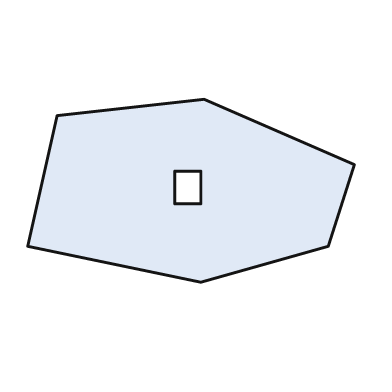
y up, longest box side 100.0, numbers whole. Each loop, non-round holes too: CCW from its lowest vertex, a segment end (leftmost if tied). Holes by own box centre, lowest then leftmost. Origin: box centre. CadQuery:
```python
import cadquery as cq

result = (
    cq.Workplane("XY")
    .moveTo(3.0, -28.0)
    .lineTo(42.0, -17.0)
    .lineTo(50.0, 8.0)
    .lineTo(4.0, 28.0)
    .lineTo(-41.0, 23.0)
    .lineTo(-50.0, -17.0)
    .close()
    .moveTo(-5.0, -4.0)
    .lineTo(3.0, -4.0)
    .lineTo(3.0, 6.0)
    .lineTo(-5.0, 6.0)
    .close()
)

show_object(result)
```